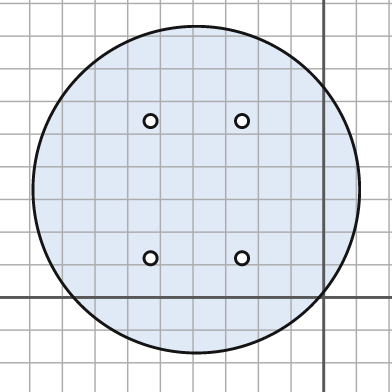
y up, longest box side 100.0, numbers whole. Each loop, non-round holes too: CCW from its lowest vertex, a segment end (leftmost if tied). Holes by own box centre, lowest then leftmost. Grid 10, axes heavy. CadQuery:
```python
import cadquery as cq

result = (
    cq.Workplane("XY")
    .moveTo(-39.0, 33.0)
    .circle(50.0)
    .moveTo(-53.0, 12.0)
    .circle(2.0)
    .moveTo(-25.0, 12.0)
    .circle(2.0)
    .moveTo(-53.0, 54.0)
    .circle(2.0)
    .moveTo(-25.0, 54.0)
    .circle(2.0)
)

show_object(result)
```